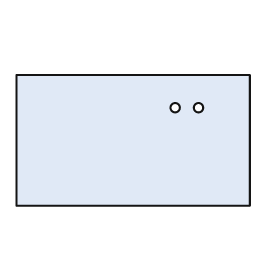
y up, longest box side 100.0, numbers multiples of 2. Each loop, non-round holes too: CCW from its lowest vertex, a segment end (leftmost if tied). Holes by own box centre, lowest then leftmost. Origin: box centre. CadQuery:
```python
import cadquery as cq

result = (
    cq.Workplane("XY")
    .moveTo(-50.0, -28.0)
    .lineTo(50.0, -28.0)
    .lineTo(50.0, 28.0)
    .lineTo(-50.0, 28.0)
    .close()
    .moveTo(18.0, 14.0)
    .circle(2.0)
    .moveTo(28.0, 14.0)
    .circle(2.0)
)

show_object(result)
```